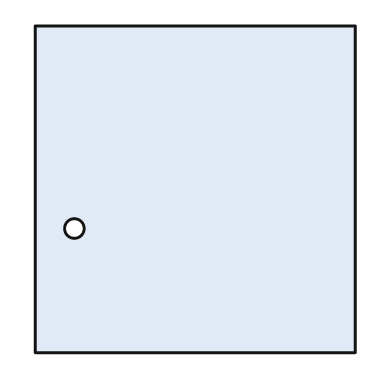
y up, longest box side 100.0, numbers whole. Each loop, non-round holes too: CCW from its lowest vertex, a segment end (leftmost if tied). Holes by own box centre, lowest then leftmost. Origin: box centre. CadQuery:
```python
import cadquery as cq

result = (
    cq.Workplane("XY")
    .moveTo(-49.0, -50.0)
    .lineTo(49.0, -50.0)
    .lineTo(49.0, 50.0)
    .lineTo(-49.0, 50.0)
    .close()
    .moveTo(-37.0, -12.0)
    .circle(3.0)
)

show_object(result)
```